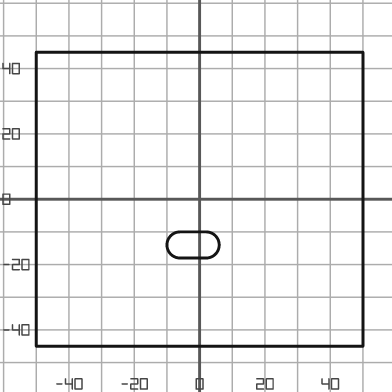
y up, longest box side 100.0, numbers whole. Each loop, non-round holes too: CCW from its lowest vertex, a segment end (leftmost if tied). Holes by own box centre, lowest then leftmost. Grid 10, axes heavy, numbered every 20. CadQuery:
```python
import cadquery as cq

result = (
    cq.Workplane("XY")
    .moveTo(-50.0, -45.0)
    .lineTo(50.0, -45.0)
    .lineTo(50.0, 45.0)
    .lineTo(-50.0, 45.0)
    .close()
    .moveTo(-6.0, -18.0)
    .lineTo(2.0, -18.0)
    .threePointArc((6.0, -14.0), (2.0, -10.0))
    .lineTo(-6.0, -10.0)
    .threePointArc((-10.0, -14.0), (-6.0, -18.0))
    .close()
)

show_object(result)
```